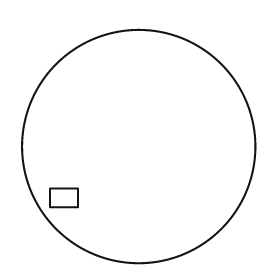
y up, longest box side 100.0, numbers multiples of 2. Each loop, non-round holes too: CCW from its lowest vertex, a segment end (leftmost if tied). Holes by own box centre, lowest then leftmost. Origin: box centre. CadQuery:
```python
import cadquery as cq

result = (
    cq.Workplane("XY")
    .moveTo(0.0, 0.0)
    .circle(50.0)
    .moveTo(-38.0, -26.0)
    .lineTo(-26.0, -26.0)
    .lineTo(-26.0, -18.0)
    .lineTo(-38.0, -18.0)
    .close()
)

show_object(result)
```